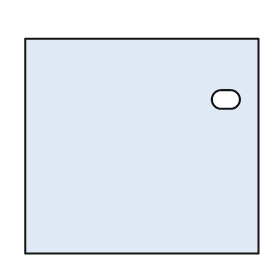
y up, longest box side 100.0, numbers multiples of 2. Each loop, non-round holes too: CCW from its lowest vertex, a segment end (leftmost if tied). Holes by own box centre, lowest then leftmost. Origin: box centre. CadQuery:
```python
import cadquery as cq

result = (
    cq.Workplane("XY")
    .moveTo(-50.0, -46.0)
    .lineTo(50.0, -46.0)
    .lineTo(50.0, 46.0)
    .lineTo(-50.0, 46.0)
    .close()
    .moveTo(34.0, 16.0)
    .lineTo(38.0, 16.0)
    .threePointArc((42.0, 20.0), (38.0, 24.0))
    .lineTo(34.0, 24.0)
    .threePointArc((30.0, 20.0), (34.0, 16.0))
    .close()
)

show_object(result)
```